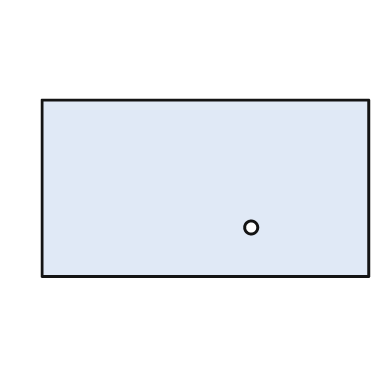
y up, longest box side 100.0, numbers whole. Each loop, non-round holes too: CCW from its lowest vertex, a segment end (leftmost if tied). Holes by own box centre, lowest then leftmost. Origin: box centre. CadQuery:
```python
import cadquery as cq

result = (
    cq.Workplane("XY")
    .moveTo(-50.0, -27.0)
    .lineTo(50.0, -27.0)
    .lineTo(50.0, 27.0)
    .lineTo(-50.0, 27.0)
    .close()
    .moveTo(14.0, -12.0)
    .circle(2.0)
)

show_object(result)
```